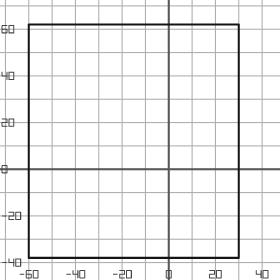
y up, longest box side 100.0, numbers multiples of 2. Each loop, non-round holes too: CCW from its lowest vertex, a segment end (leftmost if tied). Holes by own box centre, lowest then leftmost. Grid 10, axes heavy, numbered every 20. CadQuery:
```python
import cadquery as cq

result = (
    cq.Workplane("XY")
    .moveTo(-60.0, -38.0)
    .lineTo(30.0, -38.0)
    .lineTo(30.0, 62.0)
    .lineTo(-60.0, 62.0)
    .close()
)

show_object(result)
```